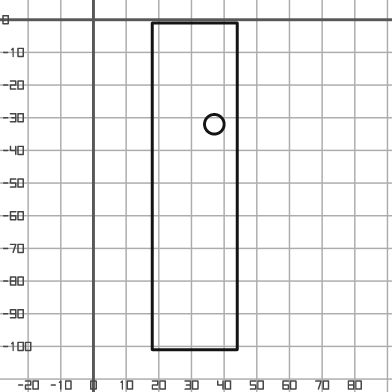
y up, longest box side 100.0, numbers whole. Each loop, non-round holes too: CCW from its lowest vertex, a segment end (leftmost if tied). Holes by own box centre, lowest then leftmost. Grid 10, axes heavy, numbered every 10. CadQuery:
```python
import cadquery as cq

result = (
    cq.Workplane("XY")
    .moveTo(18.0, -101.0)
    .lineTo(44.0, -101.0)
    .lineTo(44.0, -1.0)
    .lineTo(18.0, -1.0)
    .close()
    .moveTo(37.0, -32.0)
    .circle(3.0)
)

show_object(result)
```